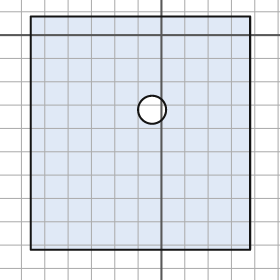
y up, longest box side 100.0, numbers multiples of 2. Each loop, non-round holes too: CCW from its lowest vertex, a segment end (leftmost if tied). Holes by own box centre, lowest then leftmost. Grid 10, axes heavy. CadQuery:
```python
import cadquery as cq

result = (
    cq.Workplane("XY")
    .moveTo(-56.0, -92.0)
    .lineTo(38.0, -92.0)
    .lineTo(38.0, 8.0)
    .lineTo(-56.0, 8.0)
    .close()
    .moveTo(-4.0, -32.0)
    .circle(6.0)
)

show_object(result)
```